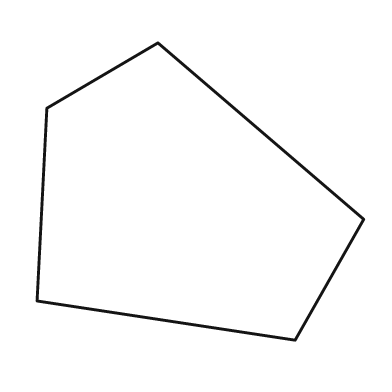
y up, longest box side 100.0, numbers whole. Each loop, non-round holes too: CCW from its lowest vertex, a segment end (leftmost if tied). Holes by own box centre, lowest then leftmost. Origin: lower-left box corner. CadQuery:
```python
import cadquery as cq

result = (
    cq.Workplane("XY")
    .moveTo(79.0, 0.0)
    .lineTo(100.0, 37.0)
    .lineTo(37.0, 91.0)
    .lineTo(3.0, 71.0)
    .lineTo(0.0, 12.0)
    .close()
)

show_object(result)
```